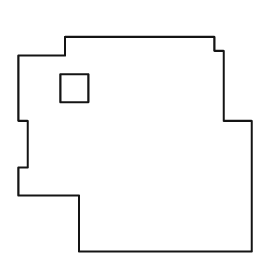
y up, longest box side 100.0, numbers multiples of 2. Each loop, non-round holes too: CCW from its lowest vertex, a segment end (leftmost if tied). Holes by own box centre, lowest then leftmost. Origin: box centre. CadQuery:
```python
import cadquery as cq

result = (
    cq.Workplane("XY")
    .moveTo(-24.0, -46.0)
    .lineTo(50.0, -46.0)
    .lineTo(50.0, 10.0)
    .lineTo(38.0, 10.0)
    .lineTo(38.0, 40.0)
    .lineTo(34.0, 40.0)
    .lineTo(34.0, 46.0)
    .lineTo(-30.0, 46.0)
    .lineTo(-30.0, 38.0)
    .lineTo(-50.0, 38.0)
    .lineTo(-50.0, 10.0)
    .lineTo(-46.0, 10.0)
    .lineTo(-46.0, -10.0)
    .lineTo(-50.0, -10.0)
    .lineTo(-50.0, -22.0)
    .lineTo(-24.0, -22.0)
    .close()
    .moveTo(-32.0, 18.0)
    .lineTo(-20.0, 18.0)
    .lineTo(-20.0, 30.0)
    .lineTo(-32.0, 30.0)
    .close()
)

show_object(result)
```